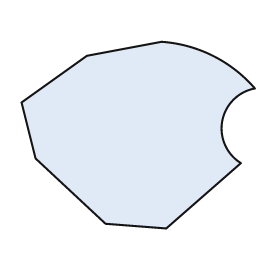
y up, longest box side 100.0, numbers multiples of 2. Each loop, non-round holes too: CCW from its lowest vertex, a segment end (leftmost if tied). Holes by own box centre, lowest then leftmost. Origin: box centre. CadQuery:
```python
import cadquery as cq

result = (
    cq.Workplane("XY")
    .moveTo(12.0, -40.0)
    .lineTo(44.0, -12.0)
    .threePointArc((36.0, 6.0), (50.0, 20.0))
    .threePointArc((32.0, 34.0), (10.0, 40.0))
    .lineTo(-22.0, 34.0)
    .lineTo(-50.0, 14.0)
    .lineTo(-44.0, -10.0)
    .lineTo(-14.0, -38.0)
    .close()
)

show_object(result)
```